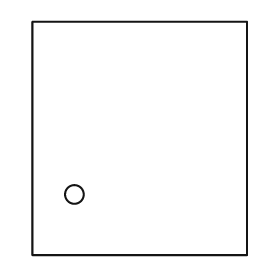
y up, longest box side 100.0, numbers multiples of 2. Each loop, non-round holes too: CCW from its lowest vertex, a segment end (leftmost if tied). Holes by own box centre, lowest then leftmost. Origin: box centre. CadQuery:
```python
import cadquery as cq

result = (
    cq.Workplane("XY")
    .moveTo(-46.0, -50.0)
    .lineTo(46.0, -50.0)
    .lineTo(46.0, 50.0)
    .lineTo(-46.0, 50.0)
    .close()
    .moveTo(-28.0, -24.0)
    .circle(4.0)
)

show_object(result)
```